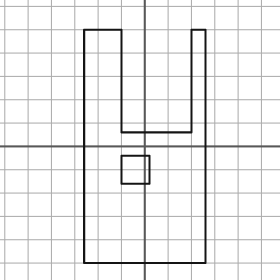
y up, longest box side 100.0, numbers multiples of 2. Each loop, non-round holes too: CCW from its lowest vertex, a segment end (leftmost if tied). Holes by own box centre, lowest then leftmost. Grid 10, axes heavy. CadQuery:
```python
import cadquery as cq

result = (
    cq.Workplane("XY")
    .moveTo(-26.0, -50.0)
    .lineTo(26.0, -50.0)
    .lineTo(26.0, 50.0)
    .lineTo(20.0, 50.0)
    .lineTo(20.0, 6.0)
    .lineTo(-10.0, 6.0)
    .lineTo(-10.0, 50.0)
    .lineTo(-26.0, 50.0)
    .close()
    .moveTo(-10.0, -16.0)
    .lineTo(2.0, -16.0)
    .lineTo(2.0, -4.0)
    .lineTo(-10.0, -4.0)
    .close()
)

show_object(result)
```